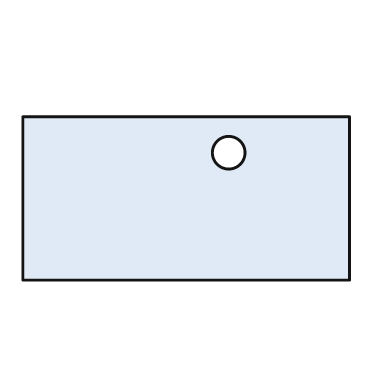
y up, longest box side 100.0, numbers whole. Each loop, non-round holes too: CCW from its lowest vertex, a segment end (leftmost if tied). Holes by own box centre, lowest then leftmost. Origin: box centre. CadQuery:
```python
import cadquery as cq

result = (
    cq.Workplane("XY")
    .moveTo(-50.0, -25.0)
    .lineTo(50.0, -25.0)
    .lineTo(50.0, 25.0)
    .lineTo(-50.0, 25.0)
    .close()
    .moveTo(13.0, 14.0)
    .circle(5.0)
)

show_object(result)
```